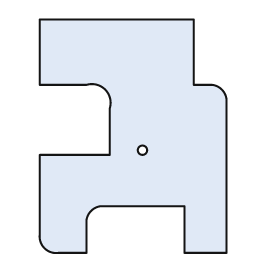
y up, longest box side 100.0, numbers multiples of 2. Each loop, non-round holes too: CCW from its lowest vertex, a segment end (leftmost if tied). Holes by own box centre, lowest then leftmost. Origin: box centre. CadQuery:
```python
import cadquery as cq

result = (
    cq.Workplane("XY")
    .moveTo(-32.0, -50.0)
    .lineTo(-20.0, -50.0)
    .lineTo(-20.0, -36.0)
    .threePointArc((-18.0, -32.0), (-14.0, -30.0))
    .lineTo(22.0, -30.0)
    .lineTo(22.0, -50.0)
    .lineTo(40.0, -50.0)
    .lineTo(40.0, 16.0)
    .threePointArc((38.0, 20.0), (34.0, 22.0))
    .lineTo(26.0, 22.0)
    .lineTo(26.0, 50.0)
    .lineTo(-40.0, 50.0)
    .lineTo(-40.0, 22.0)
    .lineTo(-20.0, 22.0)
    .threePointArc((-12.0, 20.0), (-10.0, 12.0))
    .lineTo(-10.0, -8.0)
    .lineTo(-40.0, -8.0)
    .lineTo(-40.0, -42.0)
    .threePointArc((-38.0, -48.0), (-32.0, -50.0))
    .close()
    .moveTo(4.0, -6.0)
    .circle(2.0)
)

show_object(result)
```